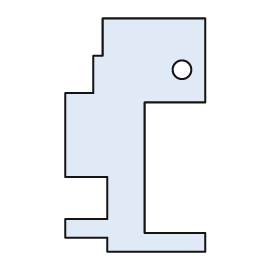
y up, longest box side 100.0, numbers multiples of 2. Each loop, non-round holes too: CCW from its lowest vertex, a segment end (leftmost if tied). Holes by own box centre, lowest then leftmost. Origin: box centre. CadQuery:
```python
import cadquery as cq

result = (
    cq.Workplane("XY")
    .moveTo(-12.0, -50.0)
    .lineTo(30.0, -50.0)
    .lineTo(30.0, -42.0)
    .lineTo(4.0, -42.0)
    .lineTo(4.0, 14.0)
    .lineTo(30.0, 14.0)
    .lineTo(30.0, 50.0)
    .lineTo(-14.0, 50.0)
    .lineTo(-14.0, 34.0)
    .lineTo(-18.0, 34.0)
    .lineTo(-18.0, 18.0)
    .lineTo(-30.0, 18.0)
    .lineTo(-30.0, -18.0)
    .lineTo(-12.0, -18.0)
    .lineTo(-12.0, -36.0)
    .lineTo(-30.0, -36.0)
    .lineTo(-30.0, -44.0)
    .lineTo(-12.0, -44.0)
    .close()
    .moveTo(20.0, 28.0)
    .circle(4.0)
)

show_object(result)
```